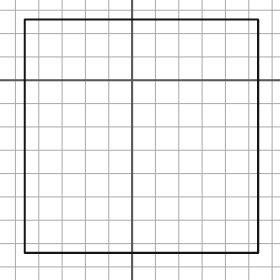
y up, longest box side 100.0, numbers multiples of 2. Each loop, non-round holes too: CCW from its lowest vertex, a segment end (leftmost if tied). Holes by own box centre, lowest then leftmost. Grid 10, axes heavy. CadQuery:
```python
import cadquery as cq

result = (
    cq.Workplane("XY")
    .moveTo(-46.0, -74.0)
    .lineTo(54.0, -74.0)
    .lineTo(54.0, 26.0)
    .lineTo(-46.0, 26.0)
    .close()
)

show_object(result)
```